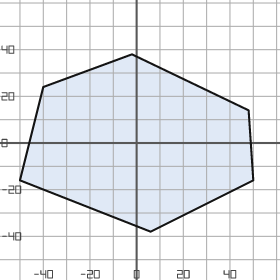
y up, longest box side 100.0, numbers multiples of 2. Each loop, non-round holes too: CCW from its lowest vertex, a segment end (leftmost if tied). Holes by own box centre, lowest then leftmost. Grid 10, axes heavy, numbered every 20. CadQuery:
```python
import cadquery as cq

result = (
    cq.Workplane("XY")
    .moveTo(6.0, -38.0)
    .lineTo(50.0, -16.0)
    .lineTo(48.0, 14.0)
    .lineTo(-2.0, 38.0)
    .lineTo(-40.0, 24.0)
    .lineTo(-50.0, -16.0)
    .close()
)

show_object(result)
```